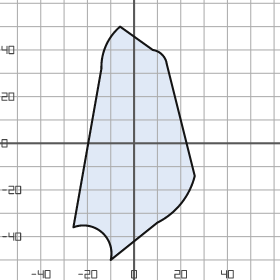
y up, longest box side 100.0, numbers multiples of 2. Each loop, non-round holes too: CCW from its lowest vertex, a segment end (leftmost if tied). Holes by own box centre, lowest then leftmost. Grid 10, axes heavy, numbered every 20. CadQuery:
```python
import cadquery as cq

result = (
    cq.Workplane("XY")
    .moveTo(-10.0, -50.0)
    .lineTo(10.0, -34.0)
    .threePointArc((20.0, -26.0), (26.0, -14.0))
    .lineTo(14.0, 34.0)
    .threePointArc((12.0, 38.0), (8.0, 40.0))
    .lineTo(-6.0, 50.0)
    .threePointArc((-12.0, 42.0), (-14.0, 32.0))
    .lineTo(-26.0, -36.0)
    .threePointArc((-14.0, -38.0), (-10.0, -50.0))
    .close()
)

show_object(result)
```